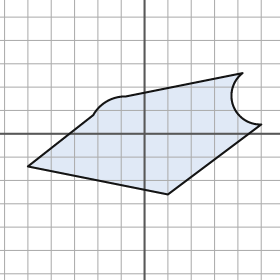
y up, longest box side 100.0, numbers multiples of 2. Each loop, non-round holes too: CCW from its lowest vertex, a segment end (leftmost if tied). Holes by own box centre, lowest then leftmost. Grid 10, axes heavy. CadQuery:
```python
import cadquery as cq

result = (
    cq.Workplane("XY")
    .moveTo(10.0, -26.0)
    .lineTo(50.0, 4.0)
    .threePointArc((38.0, 12.0), (42.0, 26.0))
    .lineTo(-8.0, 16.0)
    .threePointArc((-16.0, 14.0), (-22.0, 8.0))
    .lineTo(-50.0, -14.0)
    .close()
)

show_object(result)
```